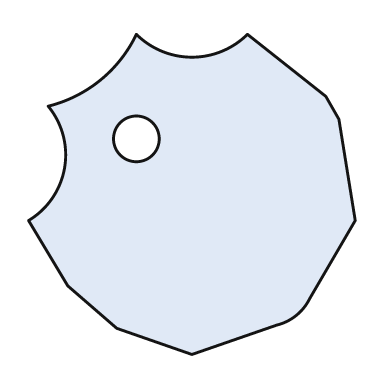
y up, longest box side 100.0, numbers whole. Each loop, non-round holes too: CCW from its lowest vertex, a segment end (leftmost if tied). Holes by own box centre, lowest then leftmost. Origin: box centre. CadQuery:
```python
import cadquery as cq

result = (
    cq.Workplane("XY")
    .moveTo(0.0, -49.0)
    .lineTo(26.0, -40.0)
    .threePointArc((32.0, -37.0), (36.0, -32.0))
    .lineTo(50.0, -8.0)
    .lineTo(45.0, 23.0)
    .lineTo(41.0, 30.0)
    .lineTo(17.0, 49.0)
    .threePointArc((0.0, 42.0), (-17.0, 49.0))
    .threePointArc((-28.0, 35.0), (-44.0, 27.0))
    .threePointArc((-39.0, 8.0), (-50.0, -8.0))
    .lineTo(-38.0, -28.0)
    .lineTo(-23.0, -41.0)
    .close()
    .moveTo(-17.0, 17.0)
    .circle(7.0)
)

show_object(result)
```